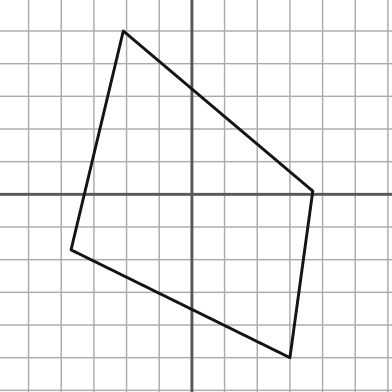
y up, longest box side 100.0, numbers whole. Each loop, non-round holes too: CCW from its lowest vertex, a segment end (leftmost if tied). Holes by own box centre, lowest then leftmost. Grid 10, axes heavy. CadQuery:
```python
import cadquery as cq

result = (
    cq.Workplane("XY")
    .moveTo(30.0, -50.0)
    .lineTo(37.0, 1.0)
    .lineTo(-21.0, 50.0)
    .lineTo(-37.0, -17.0)
    .close()
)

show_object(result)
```